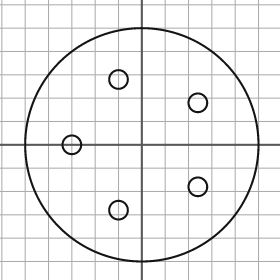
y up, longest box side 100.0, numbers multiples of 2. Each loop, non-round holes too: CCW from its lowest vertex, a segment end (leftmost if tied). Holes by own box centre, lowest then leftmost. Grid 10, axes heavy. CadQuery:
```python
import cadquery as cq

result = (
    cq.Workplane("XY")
    .moveTo(0.0, 0.0)
    .circle(50.0)
    .moveTo(-10.0, -28.0)
    .circle(4.0)
    .moveTo(24.0, -18.0)
    .circle(4.0)
    .moveTo(-30.0, 0.0)
    .circle(4.0)
    .moveTo(24.0, 18.0)
    .circle(4.0)
    .moveTo(-10.0, 28.0)
    .circle(4.0)
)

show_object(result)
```